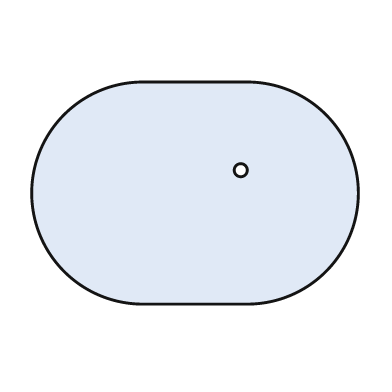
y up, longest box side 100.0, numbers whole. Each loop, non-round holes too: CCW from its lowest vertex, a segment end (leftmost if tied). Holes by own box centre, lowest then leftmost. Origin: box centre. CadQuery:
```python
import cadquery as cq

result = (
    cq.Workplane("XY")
    .moveTo(-16.0, -34.0)
    .lineTo(16.0, -34.0)
    .threePointArc((50.0, 0.0), (16.0, 34.0))
    .lineTo(-16.0, 34.0)
    .threePointArc((-50.0, 0.0), (-16.0, -34.0))
    .close()
    .moveTo(14.0, 7.0)
    .circle(2.0)
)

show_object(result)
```